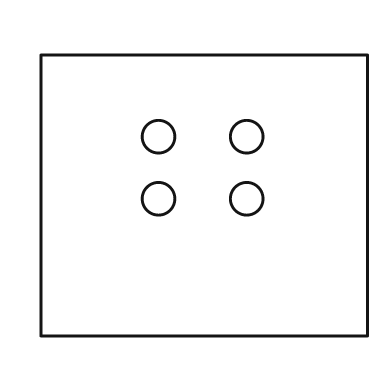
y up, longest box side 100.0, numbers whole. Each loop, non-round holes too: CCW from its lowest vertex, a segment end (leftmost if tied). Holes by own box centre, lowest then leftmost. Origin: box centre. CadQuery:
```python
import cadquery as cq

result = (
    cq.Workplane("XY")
    .moveTo(-50.0, -43.0)
    .lineTo(50.0, -43.0)
    .lineTo(50.0, 43.0)
    .lineTo(-50.0, 43.0)
    .close()
    .moveTo(-14.0, -1.0)
    .circle(5.0)
    .moveTo(13.0, -1.0)
    .circle(5.0)
    .moveTo(-14.0, 18.0)
    .circle(5.0)
    .moveTo(13.0, 18.0)
    .circle(5.0)
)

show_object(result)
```